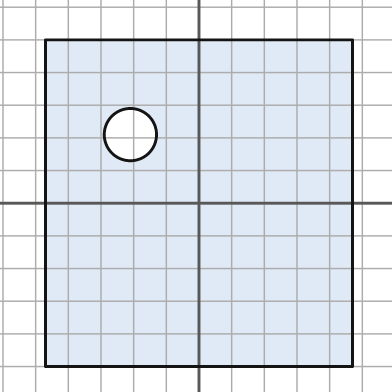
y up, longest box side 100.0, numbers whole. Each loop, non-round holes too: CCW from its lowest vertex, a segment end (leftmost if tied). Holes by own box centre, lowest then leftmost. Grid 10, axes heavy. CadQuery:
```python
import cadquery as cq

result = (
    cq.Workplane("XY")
    .moveTo(-47.0, -50.0)
    .lineTo(47.0, -50.0)
    .lineTo(47.0, 50.0)
    .lineTo(-47.0, 50.0)
    .close()
    .moveTo(-21.0, 21.0)
    .circle(8.0)
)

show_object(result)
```